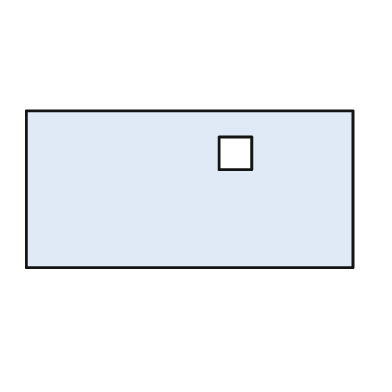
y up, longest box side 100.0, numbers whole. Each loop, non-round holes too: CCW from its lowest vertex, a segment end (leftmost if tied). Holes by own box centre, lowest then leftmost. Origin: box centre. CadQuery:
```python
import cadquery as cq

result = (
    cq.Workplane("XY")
    .moveTo(-50.0, -24.0)
    .lineTo(50.0, -24.0)
    .lineTo(50.0, 24.0)
    .lineTo(-50.0, 24.0)
    .close()
    .moveTo(9.0, 6.0)
    .lineTo(19.0, 6.0)
    .lineTo(19.0, 16.0)
    .lineTo(9.0, 16.0)
    .close()
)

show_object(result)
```